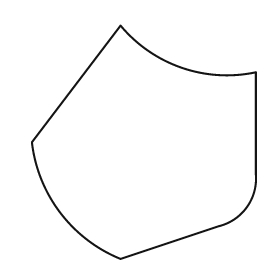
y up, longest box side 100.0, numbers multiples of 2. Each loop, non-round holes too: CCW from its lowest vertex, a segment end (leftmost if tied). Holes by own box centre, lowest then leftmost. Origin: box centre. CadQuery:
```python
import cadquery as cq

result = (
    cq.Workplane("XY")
    .moveTo(-10.0, -50.0)
    .lineTo(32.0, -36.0)
    .threePointArc((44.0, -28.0), (48.0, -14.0))
    .lineTo(48.0, 30.0)
    .threePointArc((16.0, 32.0), (-10.0, 50.0))
    .lineTo(-48.0, 0.0)
    .threePointArc((-36.0, -30.0), (-10.0, -50.0))
    .close()
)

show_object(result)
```